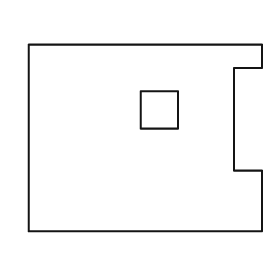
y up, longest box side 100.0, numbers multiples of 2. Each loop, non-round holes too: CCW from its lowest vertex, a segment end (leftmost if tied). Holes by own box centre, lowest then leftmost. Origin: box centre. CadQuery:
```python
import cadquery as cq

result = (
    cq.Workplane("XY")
    .moveTo(-50.0, -40.0)
    .lineTo(50.0, -40.0)
    .lineTo(50.0, -14.0)
    .lineTo(38.0, -14.0)
    .lineTo(38.0, 30.0)
    .lineTo(50.0, 30.0)
    .lineTo(50.0, 40.0)
    .lineTo(-50.0, 40.0)
    .close()
    .moveTo(-2.0, 4.0)
    .lineTo(14.0, 4.0)
    .lineTo(14.0, 20.0)
    .lineTo(-2.0, 20.0)
    .close()
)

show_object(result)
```